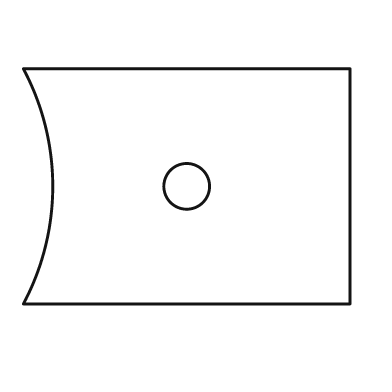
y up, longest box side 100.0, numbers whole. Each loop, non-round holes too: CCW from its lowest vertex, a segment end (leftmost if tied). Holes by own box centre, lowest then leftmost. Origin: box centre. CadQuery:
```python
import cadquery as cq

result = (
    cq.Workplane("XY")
    .moveTo(-50.0, -36.0)
    .lineTo(50.0, -36.0)
    .lineTo(50.0, 36.0)
    .lineTo(-50.0, 36.0)
    .threePointArc((-41.0, 0.0), (-50.0, -36.0))
    .close()
    .moveTo(0.0, 0.0)
    .circle(7.0)
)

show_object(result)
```